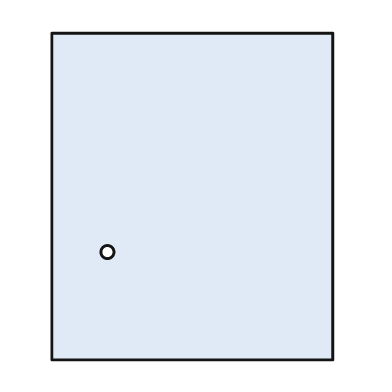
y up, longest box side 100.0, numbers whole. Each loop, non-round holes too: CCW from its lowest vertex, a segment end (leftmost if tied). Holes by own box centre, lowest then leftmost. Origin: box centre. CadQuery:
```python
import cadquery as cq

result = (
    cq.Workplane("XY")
    .moveTo(-43.0, -50.0)
    .lineTo(43.0, -50.0)
    .lineTo(43.0, 50.0)
    .lineTo(-43.0, 50.0)
    .close()
    .moveTo(-26.0, -17.0)
    .circle(2.0)
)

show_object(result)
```